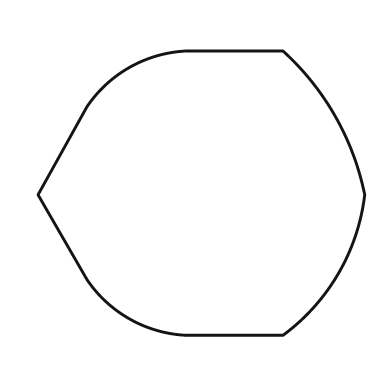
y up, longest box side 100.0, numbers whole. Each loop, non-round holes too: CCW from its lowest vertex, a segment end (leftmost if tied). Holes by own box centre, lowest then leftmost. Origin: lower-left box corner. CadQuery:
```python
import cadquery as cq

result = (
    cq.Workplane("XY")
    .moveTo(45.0, 0.0)
    .lineTo(75.0, 0.0)
    .threePointArc((92.0, 19.0), (100.0, 43.0))
    .threePointArc((91.0, 67.0), (75.0, 87.0))
    .lineTo(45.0, 87.0)
    .threePointArc((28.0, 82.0), (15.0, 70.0))
    .lineTo(0.0, 43.0)
    .lineTo(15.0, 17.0)
    .threePointArc((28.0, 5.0), (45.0, 0.0))
    .close()
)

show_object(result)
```